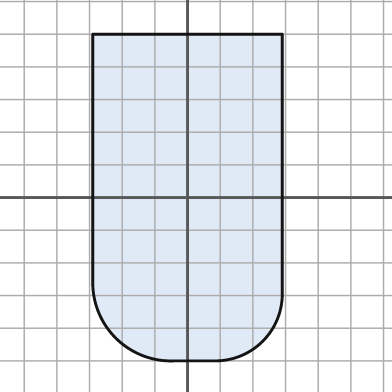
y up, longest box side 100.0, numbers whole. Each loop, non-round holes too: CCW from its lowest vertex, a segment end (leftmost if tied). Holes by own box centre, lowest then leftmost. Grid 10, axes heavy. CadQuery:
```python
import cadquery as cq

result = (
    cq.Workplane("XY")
    .moveTo(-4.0, -50.0)
    .lineTo(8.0, -50.0)
    .threePointArc((23.0, -44.0), (29.0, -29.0))
    .lineTo(29.0, 50.0)
    .lineTo(-29.0, 50.0)
    .lineTo(-29.0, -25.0)
    .threePointArc((-22.0, -43.0), (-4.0, -50.0))
    .close()
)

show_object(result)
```